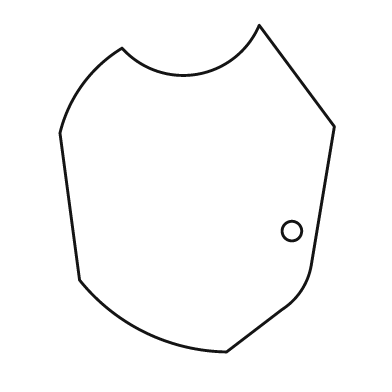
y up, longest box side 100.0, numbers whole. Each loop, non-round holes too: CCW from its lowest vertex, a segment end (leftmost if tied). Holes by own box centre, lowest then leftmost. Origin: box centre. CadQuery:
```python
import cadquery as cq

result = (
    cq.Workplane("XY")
    .moveTo(9.0, -50.0)
    .lineTo(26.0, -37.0)
    .threePointArc((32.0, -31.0), (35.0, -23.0))
    .lineTo(42.0, 19.0)
    .lineTo(19.0, 50.0)
    .threePointArc((0.0, 35.0), (-23.0, 43.0))
    .threePointArc((-35.0, 32.0), (-42.0, 17.0))
    .lineTo(-36.0, -28.0)
    .threePointArc((-16.0, -44.0), (9.0, -50.0))
    .close()
    .moveTo(29.0, -13.0)
    .circle(3.0)
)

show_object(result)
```